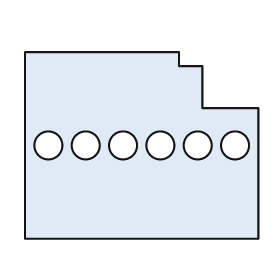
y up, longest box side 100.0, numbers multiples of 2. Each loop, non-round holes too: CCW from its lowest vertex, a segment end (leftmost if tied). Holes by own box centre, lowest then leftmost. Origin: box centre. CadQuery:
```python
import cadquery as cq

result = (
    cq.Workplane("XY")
    .moveTo(-50.0, -40.0)
    .lineTo(50.0, -40.0)
    .lineTo(50.0, 16.0)
    .lineTo(26.0, 16.0)
    .lineTo(26.0, 34.0)
    .lineTo(16.0, 34.0)
    .lineTo(16.0, 40.0)
    .lineTo(-50.0, 40.0)
    .close()
    .moveTo(-40.0, 0.0)
    .circle(6.0)
    .moveTo(-24.0, 0.0)
    .circle(6.0)
    .moveTo(-8.0, 0.0)
    .circle(6.0)
    .moveTo(8.0, 0.0)
    .circle(6.0)
    .moveTo(24.0, 0.0)
    .circle(6.0)
    .moveTo(40.0, 0.0)
    .circle(6.0)
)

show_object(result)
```